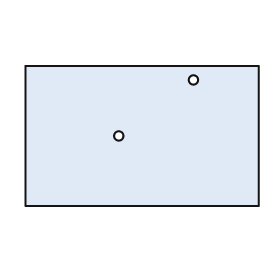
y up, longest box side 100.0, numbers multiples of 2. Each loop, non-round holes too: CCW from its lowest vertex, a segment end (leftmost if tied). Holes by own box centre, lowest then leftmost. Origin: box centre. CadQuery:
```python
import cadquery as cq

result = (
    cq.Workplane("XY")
    .moveTo(-50.0, -30.0)
    .lineTo(50.0, -30.0)
    .lineTo(50.0, 30.0)
    .lineTo(-50.0, 30.0)
    .close()
    .moveTo(-10.0, 0.0)
    .circle(2.0)
    .moveTo(22.0, 24.0)
    .circle(2.0)
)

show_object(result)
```